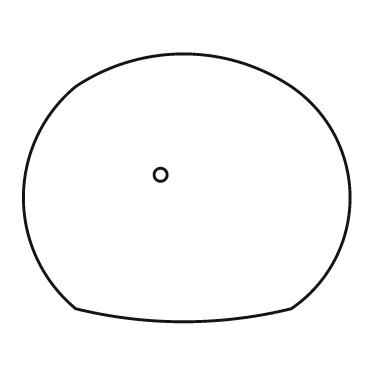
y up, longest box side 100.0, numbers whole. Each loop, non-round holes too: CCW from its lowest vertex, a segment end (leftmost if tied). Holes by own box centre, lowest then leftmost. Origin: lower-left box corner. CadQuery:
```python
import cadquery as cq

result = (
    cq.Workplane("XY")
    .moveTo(16.0, 4.0)
    .threePointArc((49.0, 0.0), (82.0, 4.0))
    .threePointArc((100.0, 38.0), (82.0, 72.0))
    .threePointArc((49.0, 82.0), (16.0, 72.0))
    .threePointArc((0.0, 38.0), (16.0, 4.0))
    .close()
    .moveTo(42.0, 45.0)
    .circle(2.0)
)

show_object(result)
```